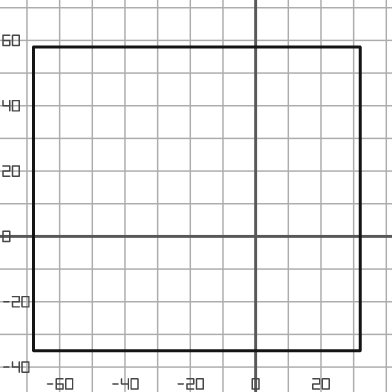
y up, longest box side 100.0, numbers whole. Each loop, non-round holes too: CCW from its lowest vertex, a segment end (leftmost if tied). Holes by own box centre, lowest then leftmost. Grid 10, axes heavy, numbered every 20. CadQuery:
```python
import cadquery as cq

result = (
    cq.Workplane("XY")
    .moveTo(-68.0, -35.0)
    .lineTo(32.0, -35.0)
    .lineTo(32.0, 58.0)
    .lineTo(-68.0, 58.0)
    .close()
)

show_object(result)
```